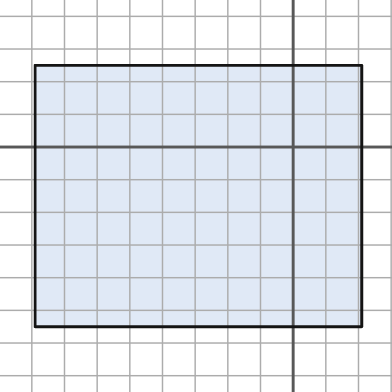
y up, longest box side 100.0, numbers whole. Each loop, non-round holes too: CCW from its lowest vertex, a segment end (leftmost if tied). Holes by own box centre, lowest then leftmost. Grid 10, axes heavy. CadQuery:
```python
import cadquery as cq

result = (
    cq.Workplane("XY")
    .moveTo(-79.0, -55.0)
    .lineTo(21.0, -55.0)
    .lineTo(21.0, 25.0)
    .lineTo(-79.0, 25.0)
    .close()
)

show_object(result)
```